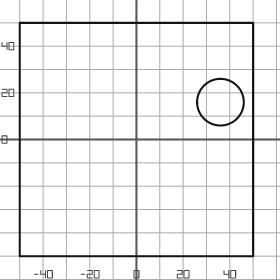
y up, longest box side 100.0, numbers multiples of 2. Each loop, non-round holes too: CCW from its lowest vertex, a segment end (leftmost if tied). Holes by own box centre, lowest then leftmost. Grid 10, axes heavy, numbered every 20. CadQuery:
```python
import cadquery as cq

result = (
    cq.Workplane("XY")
    .moveTo(-50.0, -50.0)
    .lineTo(50.0, -50.0)
    .lineTo(50.0, 50.0)
    .lineTo(-50.0, 50.0)
    .close()
    .moveTo(36.0, 16.0)
    .circle(10.0)
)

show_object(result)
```